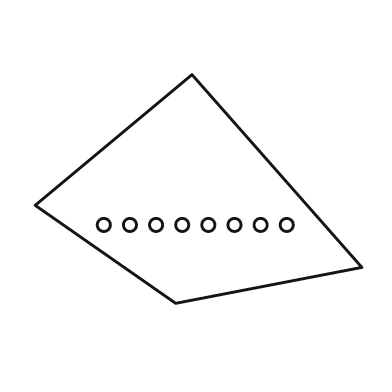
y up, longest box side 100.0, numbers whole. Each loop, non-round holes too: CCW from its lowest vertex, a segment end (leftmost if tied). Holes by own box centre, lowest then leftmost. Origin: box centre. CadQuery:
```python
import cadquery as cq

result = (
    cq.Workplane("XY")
    .moveTo(-7.0, -35.0)
    .lineTo(50.0, -24.0)
    .lineTo(-2.0, 35.0)
    .lineTo(-50.0, -5.0)
    .close()
    .moveTo(-29.0, -11.0)
    .circle(2.0)
    .moveTo(-21.0, -11.0)
    .circle(2.0)
    .moveTo(-13.0, -11.0)
    .circle(2.0)
    .moveTo(-5.0, -11.0)
    .circle(2.0)
    .moveTo(3.0, -11.0)
    .circle(2.0)
    .moveTo(11.0, -11.0)
    .circle(2.0)
    .moveTo(19.0, -11.0)
    .circle(2.0)
    .moveTo(27.0, -11.0)
    .circle(2.0)
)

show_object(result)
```